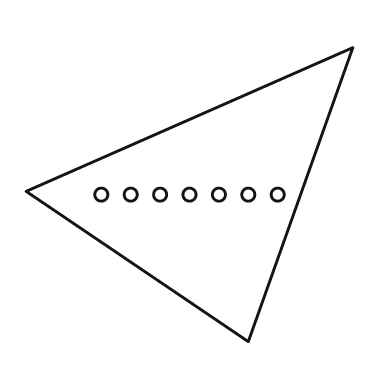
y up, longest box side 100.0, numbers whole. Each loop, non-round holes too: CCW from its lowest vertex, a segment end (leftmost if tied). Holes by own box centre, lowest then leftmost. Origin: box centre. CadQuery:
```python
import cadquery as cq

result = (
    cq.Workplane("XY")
    .moveTo(18.0, -45.0)
    .lineTo(50.0, 45.0)
    .lineTo(-50.0, 1.0)
    .close()
    .moveTo(-27.0, 0.0)
    .circle(2.0)
    .moveTo(-18.0, 0.0)
    .circle(2.0)
    .moveTo(-9.0, 0.0)
    .circle(2.0)
    .moveTo(0.0, 0.0)
    .circle(2.0)
    .moveTo(9.0, 0.0)
    .circle(2.0)
    .moveTo(18.0, 0.0)
    .circle(2.0)
    .moveTo(27.0, 0.0)
    .circle(2.0)
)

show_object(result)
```